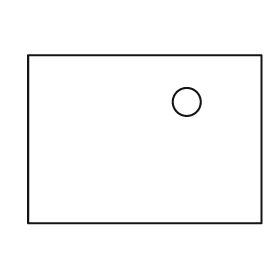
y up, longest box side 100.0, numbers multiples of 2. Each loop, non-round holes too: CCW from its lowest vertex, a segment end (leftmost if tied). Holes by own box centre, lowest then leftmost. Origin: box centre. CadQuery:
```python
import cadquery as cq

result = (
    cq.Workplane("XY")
    .moveTo(-50.0, -36.0)
    .lineTo(50.0, -36.0)
    .lineTo(50.0, 36.0)
    .lineTo(-50.0, 36.0)
    .close()
    .moveTo(18.0, 16.0)
    .circle(6.0)
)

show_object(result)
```